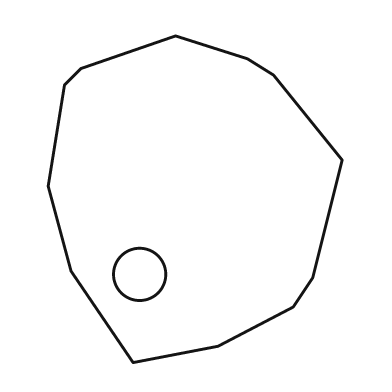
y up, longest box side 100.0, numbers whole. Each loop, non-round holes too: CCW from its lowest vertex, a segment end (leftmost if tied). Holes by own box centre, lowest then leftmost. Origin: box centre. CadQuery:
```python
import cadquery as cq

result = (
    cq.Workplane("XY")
    .moveTo(-19.0, -50.0)
    .lineTo(7.0, -45.0)
    .lineTo(30.0, -33.0)
    .lineTo(36.0, -24.0)
    .lineTo(45.0, 12.0)
    .lineTo(24.0, 38.0)
    .lineTo(16.0, 43.0)
    .lineTo(-6.0, 50.0)
    .lineTo(-35.0, 40.0)
    .lineTo(-40.0, 35.0)
    .lineTo(-45.0, 4.0)
    .lineTo(-38.0, -22.0)
    .close()
    .moveTo(-17.0, -23.0)
    .circle(8.0)
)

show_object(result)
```